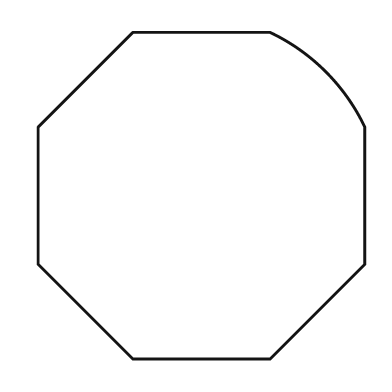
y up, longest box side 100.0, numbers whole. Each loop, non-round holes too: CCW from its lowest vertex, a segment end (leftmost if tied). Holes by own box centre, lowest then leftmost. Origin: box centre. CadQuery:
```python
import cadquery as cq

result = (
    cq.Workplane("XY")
    .moveTo(-21.0, -50.0)
    .lineTo(21.0, -50.0)
    .lineTo(50.0, -21.0)
    .lineTo(50.0, 21.0)
    .threePointArc((38.0, 38.0), (21.0, 50.0))
    .lineTo(-21.0, 50.0)
    .lineTo(-50.0, 21.0)
    .lineTo(-50.0, -21.0)
    .close()
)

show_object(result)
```